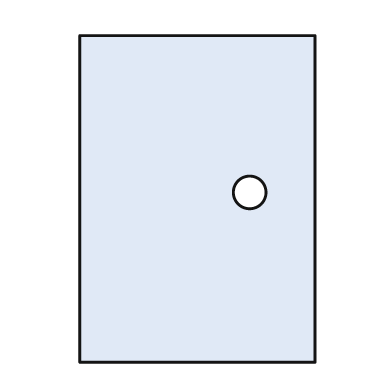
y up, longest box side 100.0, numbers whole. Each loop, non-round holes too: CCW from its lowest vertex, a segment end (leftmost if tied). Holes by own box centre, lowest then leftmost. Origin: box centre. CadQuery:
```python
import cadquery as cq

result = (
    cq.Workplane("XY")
    .moveTo(-36.0, -50.0)
    .lineTo(36.0, -50.0)
    .lineTo(36.0, 50.0)
    .lineTo(-36.0, 50.0)
    .close()
    .moveTo(16.0, 2.0)
    .circle(5.0)
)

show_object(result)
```